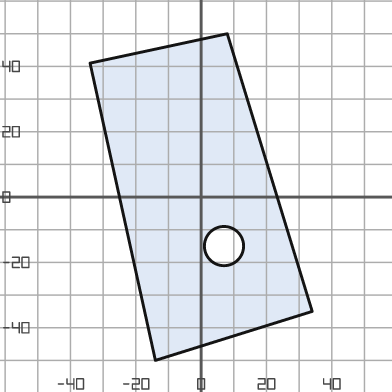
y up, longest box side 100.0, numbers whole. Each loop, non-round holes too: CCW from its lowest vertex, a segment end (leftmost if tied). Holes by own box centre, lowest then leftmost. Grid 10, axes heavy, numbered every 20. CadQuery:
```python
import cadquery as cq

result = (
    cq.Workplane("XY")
    .moveTo(-14.0, -50.0)
    .lineTo(34.0, -35.0)
    .lineTo(8.0, 50.0)
    .lineTo(-34.0, 41.0)
    .close()
    .moveTo(7.0, -15.0)
    .circle(6.0)
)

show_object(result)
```